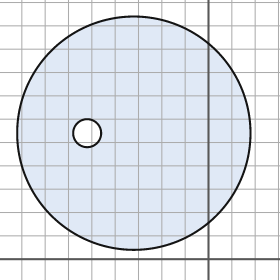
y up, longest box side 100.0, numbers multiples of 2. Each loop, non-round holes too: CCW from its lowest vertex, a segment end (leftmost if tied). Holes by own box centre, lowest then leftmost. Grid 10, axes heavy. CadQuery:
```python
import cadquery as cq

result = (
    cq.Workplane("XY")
    .moveTo(-32.0, 54.0)
    .circle(50.0)
    .moveTo(-52.0, 54.0)
    .circle(6.0)
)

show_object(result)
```